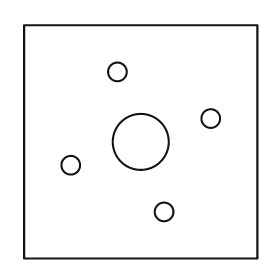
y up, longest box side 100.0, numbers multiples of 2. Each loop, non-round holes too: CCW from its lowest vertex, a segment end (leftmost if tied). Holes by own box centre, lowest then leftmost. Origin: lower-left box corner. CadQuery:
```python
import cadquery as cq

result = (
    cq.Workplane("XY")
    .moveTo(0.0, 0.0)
    .lineTo(100.0, 0.0)
    .lineTo(100.0, 100.0)
    .lineTo(0.0, 100.0)
    .close()
    .moveTo(60.0, 20.0)
    .circle(4.0)
    .moveTo(20.0, 40.0)
    .circle(4.0)
    .moveTo(50.0, 50.0)
    .circle(12.0)
    .moveTo(80.0, 60.0)
    .circle(4.0)
    .moveTo(40.0, 80.0)
    .circle(4.0)
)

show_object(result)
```